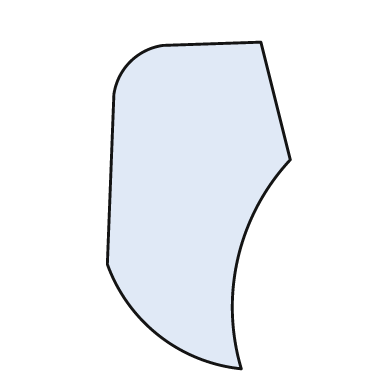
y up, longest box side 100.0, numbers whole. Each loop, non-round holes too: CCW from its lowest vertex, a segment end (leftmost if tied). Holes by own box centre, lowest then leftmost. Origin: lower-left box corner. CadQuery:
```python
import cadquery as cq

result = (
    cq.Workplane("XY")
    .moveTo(41.0, 0.0)
    .threePointArc((40.0, 34.0), (56.0, 64.0))
    .lineTo(47.0, 100.0)
    .lineTo(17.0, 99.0)
    .threePointArc((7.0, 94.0), (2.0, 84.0))
    .lineTo(0.0, 32.0)
    .threePointArc((16.0, 10.0), (41.0, 0.0))
    .close()
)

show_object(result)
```